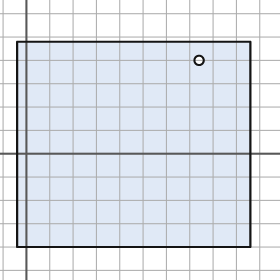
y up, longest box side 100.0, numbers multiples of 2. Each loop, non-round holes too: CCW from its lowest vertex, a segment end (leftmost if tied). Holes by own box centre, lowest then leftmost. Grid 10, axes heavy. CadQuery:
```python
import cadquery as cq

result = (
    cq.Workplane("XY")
    .moveTo(-4.0, -40.0)
    .lineTo(96.0, -40.0)
    .lineTo(96.0, 48.0)
    .lineTo(-4.0, 48.0)
    .close()
    .moveTo(74.0, 40.0)
    .circle(2.0)
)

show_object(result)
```